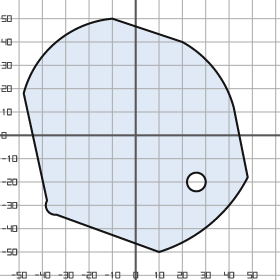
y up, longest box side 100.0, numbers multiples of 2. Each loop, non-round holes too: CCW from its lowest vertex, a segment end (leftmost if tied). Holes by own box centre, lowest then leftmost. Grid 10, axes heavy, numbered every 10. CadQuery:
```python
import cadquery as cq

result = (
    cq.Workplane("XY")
    .moveTo(10.0, -50.0)
    .threePointArc((32.0, -38.0), (48.0, -18.0))
    .lineTo(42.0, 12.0)
    .threePointArc((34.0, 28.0), (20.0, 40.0))
    .lineTo(-10.0, 50.0)
    .threePointArc((-34.0, 40.0), (-48.0, 18.0))
    .lineTo(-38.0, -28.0)
    .threePointArc((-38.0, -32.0), (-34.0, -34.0))
    .close()
    .moveTo(26.0, -20.0)
    .circle(4.0)
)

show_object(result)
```